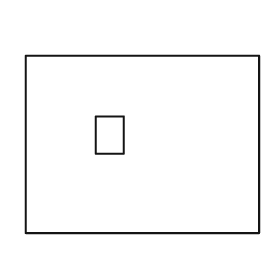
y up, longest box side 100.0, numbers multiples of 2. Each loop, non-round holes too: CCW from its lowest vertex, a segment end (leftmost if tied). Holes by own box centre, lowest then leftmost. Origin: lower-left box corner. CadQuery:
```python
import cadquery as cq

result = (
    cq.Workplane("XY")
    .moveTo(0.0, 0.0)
    .lineTo(100.0, 0.0)
    .lineTo(100.0, 76.0)
    .lineTo(0.0, 76.0)
    .close()
    .moveTo(30.0, 34.0)
    .lineTo(42.0, 34.0)
    .lineTo(42.0, 50.0)
    .lineTo(30.0, 50.0)
    .close()
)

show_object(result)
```